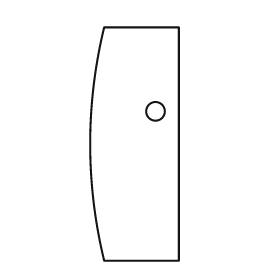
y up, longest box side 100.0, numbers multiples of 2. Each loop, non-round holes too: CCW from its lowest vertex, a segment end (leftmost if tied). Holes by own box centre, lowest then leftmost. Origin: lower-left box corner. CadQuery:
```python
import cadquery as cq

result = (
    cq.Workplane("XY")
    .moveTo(6.0, 0.0)
    .lineTo(38.0, 0.0)
    .lineTo(38.0, 100.0)
    .lineTo(6.0, 100.0)
    .threePointArc((0.0, 50.0), (6.0, 0.0))
    .close()
    .moveTo(28.0, 64.0)
    .circle(4.0)
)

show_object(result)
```